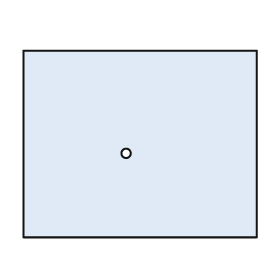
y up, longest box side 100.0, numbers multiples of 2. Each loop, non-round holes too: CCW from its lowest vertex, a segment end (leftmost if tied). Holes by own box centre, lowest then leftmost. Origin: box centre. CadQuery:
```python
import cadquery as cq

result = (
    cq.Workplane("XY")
    .moveTo(-50.0, -40.0)
    .lineTo(50.0, -40.0)
    .lineTo(50.0, 40.0)
    .lineTo(-50.0, 40.0)
    .close()
    .moveTo(-6.0, -4.0)
    .circle(2.0)
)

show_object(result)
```